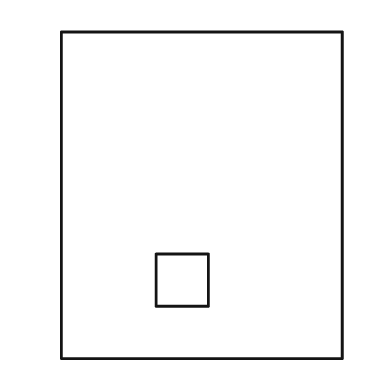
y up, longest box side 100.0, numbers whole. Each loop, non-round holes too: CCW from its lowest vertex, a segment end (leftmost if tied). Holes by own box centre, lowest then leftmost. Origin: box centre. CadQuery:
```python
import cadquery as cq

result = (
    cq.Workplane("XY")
    .moveTo(-43.0, -50.0)
    .lineTo(43.0, -50.0)
    .lineTo(43.0, 50.0)
    .lineTo(-43.0, 50.0)
    .close()
    .moveTo(-14.0, -34.0)
    .lineTo(2.0, -34.0)
    .lineTo(2.0, -18.0)
    .lineTo(-14.0, -18.0)
    .close()
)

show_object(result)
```